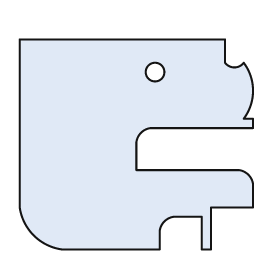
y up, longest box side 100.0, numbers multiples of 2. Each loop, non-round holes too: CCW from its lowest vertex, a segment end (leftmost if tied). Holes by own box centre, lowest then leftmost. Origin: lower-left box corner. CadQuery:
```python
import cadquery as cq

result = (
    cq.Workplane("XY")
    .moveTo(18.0, 0.0)
    .lineTo(60.0, 0.0)
    .lineTo(60.0, 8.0)
    .threePointArc((62.0, 12.0), (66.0, 14.0))
    .lineTo(78.0, 14.0)
    .lineTo(78.0, 0.0)
    .lineTo(82.0, 0.0)
    .lineTo(82.0, 18.0)
    .lineTo(100.0, 18.0)
    .lineTo(100.0, 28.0)
    .threePointArc((98.0, 32.0), (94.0, 34.0))
    .lineTo(50.0, 34.0)
    .lineTo(50.0, 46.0)
    .threePointArc((52.0, 50.0), (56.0, 52.0))
    .lineTo(100.0, 52.0)
    .lineTo(100.0, 56.0)
    .lineTo(96.0, 56.0)
    .threePointArc((100.0, 68.0), (96.0, 80.0))
    .threePointArc((92.0, 78.0), (88.0, 80.0))
    .lineTo(88.0, 90.0)
    .lineTo(0.0, 90.0)
    .lineTo(0.0, 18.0)
    .threePointArc((6.0, 6.0), (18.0, 0.0))
    .close()
    .moveTo(58.0, 76.0)
    .circle(4.0)
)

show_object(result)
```